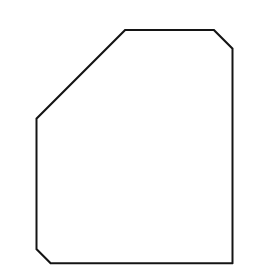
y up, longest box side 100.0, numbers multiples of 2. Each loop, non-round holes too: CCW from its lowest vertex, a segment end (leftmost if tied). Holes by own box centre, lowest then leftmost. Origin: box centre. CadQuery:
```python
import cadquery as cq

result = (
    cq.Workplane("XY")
    .moveTo(-36.0, -50.0)
    .lineTo(42.0, -50.0)
    .lineTo(42.0, 42.0)
    .lineTo(34.0, 50.0)
    .lineTo(-4.0, 50.0)
    .lineTo(-42.0, 12.0)
    .lineTo(-42.0, -44.0)
    .close()
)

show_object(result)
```